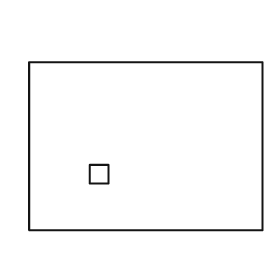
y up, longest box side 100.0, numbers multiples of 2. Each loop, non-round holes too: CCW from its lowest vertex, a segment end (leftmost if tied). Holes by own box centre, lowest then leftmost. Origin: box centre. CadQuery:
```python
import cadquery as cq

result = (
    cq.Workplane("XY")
    .moveTo(-50.0, -36.0)
    .lineTo(50.0, -36.0)
    .lineTo(50.0, 36.0)
    .lineTo(-50.0, 36.0)
    .close()
    .moveTo(-24.0, -16.0)
    .lineTo(-16.0, -16.0)
    .lineTo(-16.0, -8.0)
    .lineTo(-24.0, -8.0)
    .close()
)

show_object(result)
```